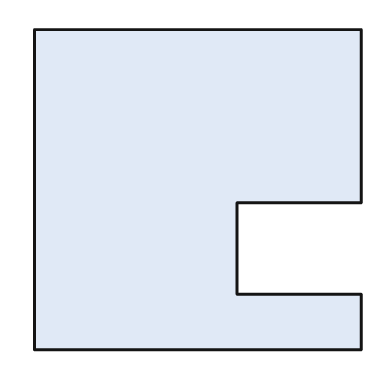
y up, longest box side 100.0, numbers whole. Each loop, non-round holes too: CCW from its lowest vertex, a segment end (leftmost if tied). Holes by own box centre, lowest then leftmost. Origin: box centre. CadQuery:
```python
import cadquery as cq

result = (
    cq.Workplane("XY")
    .moveTo(-50.0, -49.0)
    .lineTo(50.0, -49.0)
    .lineTo(50.0, -32.0)
    .lineTo(12.0, -32.0)
    .lineTo(12.0, -4.0)
    .lineTo(50.0, -4.0)
    .lineTo(50.0, 49.0)
    .lineTo(-50.0, 49.0)
    .close()
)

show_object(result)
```